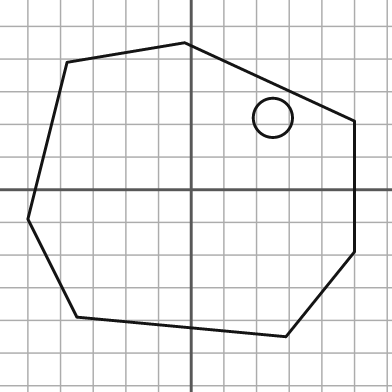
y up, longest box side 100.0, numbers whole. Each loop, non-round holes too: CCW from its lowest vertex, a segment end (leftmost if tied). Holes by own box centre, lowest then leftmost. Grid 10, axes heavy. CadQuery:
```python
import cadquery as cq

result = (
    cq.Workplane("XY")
    .moveTo(29.0, -45.0)
    .lineTo(50.0, -19.0)
    .lineTo(50.0, 21.0)
    .lineTo(-2.0, 45.0)
    .lineTo(-38.0, 39.0)
    .lineTo(-50.0, -9.0)
    .lineTo(-35.0, -39.0)
    .close()
    .moveTo(25.0, 22.0)
    .circle(6.0)
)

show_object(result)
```